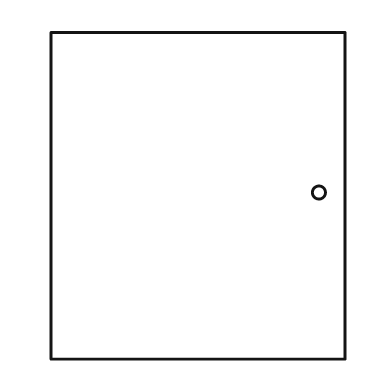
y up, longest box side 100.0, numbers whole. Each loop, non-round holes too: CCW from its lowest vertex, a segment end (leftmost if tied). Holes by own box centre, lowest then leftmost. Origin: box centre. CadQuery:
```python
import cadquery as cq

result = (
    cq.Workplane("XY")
    .moveTo(-45.0, -50.0)
    .lineTo(45.0, -50.0)
    .lineTo(45.0, 50.0)
    .lineTo(-45.0, 50.0)
    .close()
    .moveTo(37.0, 1.0)
    .circle(2.0)
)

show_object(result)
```